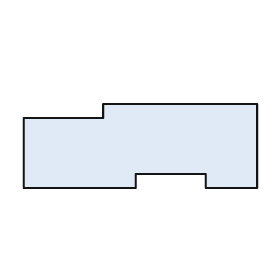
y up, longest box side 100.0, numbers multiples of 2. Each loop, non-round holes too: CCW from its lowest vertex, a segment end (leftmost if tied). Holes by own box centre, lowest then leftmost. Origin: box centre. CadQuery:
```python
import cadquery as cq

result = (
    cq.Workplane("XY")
    .moveTo(-50.0, -18.0)
    .lineTo(-2.0, -18.0)
    .lineTo(-2.0, -12.0)
    .lineTo(28.0, -12.0)
    .lineTo(28.0, -18.0)
    .lineTo(50.0, -18.0)
    .lineTo(50.0, 18.0)
    .lineTo(-16.0, 18.0)
    .lineTo(-16.0, 12.0)
    .lineTo(-50.0, 12.0)
    .close()
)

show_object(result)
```